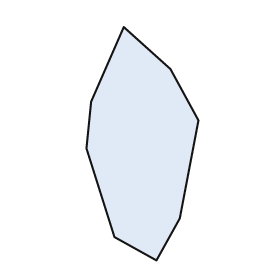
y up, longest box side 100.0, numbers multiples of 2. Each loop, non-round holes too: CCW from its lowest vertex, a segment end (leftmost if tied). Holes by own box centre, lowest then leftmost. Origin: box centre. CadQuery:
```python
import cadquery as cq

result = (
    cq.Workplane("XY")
    .moveTo(6.0, -50.0)
    .lineTo(16.0, -32.0)
    .lineTo(24.0, 10.0)
    .lineTo(12.0, 32.0)
    .lineTo(-8.0, 50.0)
    .lineTo(-22.0, 18.0)
    .lineTo(-24.0, -2.0)
    .lineTo(-12.0, -40.0)
    .close()
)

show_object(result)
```